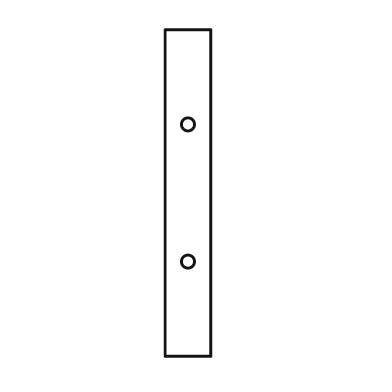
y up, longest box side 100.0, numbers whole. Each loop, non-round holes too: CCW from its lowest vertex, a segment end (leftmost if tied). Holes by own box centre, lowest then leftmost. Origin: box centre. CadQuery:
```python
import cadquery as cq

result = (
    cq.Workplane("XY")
    .moveTo(-7.0, -50.0)
    .lineTo(7.0, -50.0)
    .lineTo(7.0, 50.0)
    .lineTo(-7.0, 50.0)
    .close()
    .moveTo(0.0, -21.0)
    .circle(2.0)
    .moveTo(0.0, 21.0)
    .circle(2.0)
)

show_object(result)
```